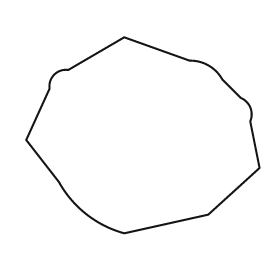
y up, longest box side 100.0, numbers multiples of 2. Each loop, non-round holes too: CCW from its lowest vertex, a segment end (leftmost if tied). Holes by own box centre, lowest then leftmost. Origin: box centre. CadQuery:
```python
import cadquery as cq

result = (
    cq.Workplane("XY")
    .moveTo(-8.0, -42.0)
    .lineTo(28.0, -34.0)
    .lineTo(50.0, -14.0)
    .lineTo(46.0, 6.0)
    .threePointArc((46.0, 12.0), (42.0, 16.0))
    .lineTo(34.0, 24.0)
    .threePointArc((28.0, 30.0), (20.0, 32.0))
    .lineTo(-8.0, 42.0)
    .lineTo(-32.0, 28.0)
    .threePointArc((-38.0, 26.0), (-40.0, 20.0))
    .lineTo(-50.0, -2.0)
    .lineTo(-36.0, -20.0)
    .threePointArc((-24.0, -34.0), (-8.0, -42.0))
    .close()
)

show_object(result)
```